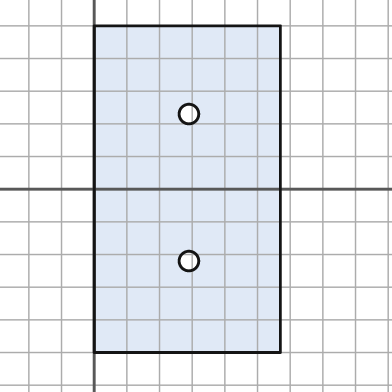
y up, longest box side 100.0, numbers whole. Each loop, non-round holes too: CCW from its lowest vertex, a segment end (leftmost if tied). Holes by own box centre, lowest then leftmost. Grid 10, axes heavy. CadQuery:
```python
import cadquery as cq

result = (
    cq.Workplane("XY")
    .moveTo(0.0, -50.0)
    .lineTo(57.0, -50.0)
    .lineTo(57.0, 50.0)
    .lineTo(0.0, 50.0)
    .close()
    .moveTo(29.0, -22.0)
    .circle(3.0)
    .moveTo(29.0, 23.0)
    .circle(3.0)
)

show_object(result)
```